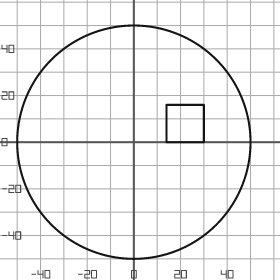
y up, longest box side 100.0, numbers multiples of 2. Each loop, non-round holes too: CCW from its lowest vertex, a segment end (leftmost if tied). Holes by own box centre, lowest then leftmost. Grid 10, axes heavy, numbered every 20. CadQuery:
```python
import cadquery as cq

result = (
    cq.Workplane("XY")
    .moveTo(0.0, 0.0)
    .circle(50.0)
    .moveTo(14.0, 0.0)
    .lineTo(30.0, 0.0)
    .lineTo(30.0, 16.0)
    .lineTo(14.0, 16.0)
    .close()
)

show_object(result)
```